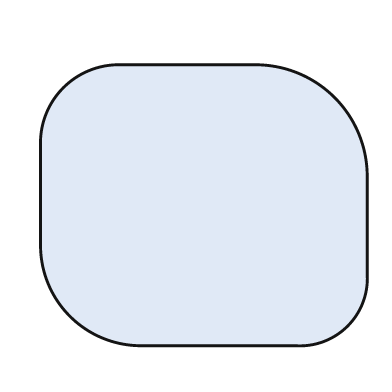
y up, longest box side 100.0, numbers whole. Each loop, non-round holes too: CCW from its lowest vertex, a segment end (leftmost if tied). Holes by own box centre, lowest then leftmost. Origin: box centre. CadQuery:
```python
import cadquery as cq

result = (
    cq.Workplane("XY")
    .moveTo(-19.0, -43.0)
    .lineTo(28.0, -43.0)
    .threePointArc((44.0, -37.0), (50.0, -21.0))
    .lineTo(50.0, 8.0)
    .threePointArc((40.0, 33.0), (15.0, 43.0))
    .lineTo(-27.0, 43.0)
    .threePointArc((-43.0, 36.0), (-50.0, 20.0))
    .lineTo(-50.0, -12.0)
    .threePointArc((-41.0, -34.0), (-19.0, -43.0))
    .close()
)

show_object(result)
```